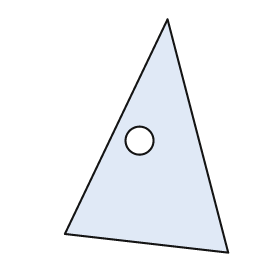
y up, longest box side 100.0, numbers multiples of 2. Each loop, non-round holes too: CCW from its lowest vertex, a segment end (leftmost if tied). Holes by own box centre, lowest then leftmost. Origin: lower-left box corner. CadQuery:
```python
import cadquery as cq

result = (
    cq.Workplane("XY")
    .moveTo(70.0, 0.0)
    .lineTo(44.0, 100.0)
    .lineTo(0.0, 8.0)
    .close()
    .moveTo(32.0, 48.0)
    .circle(6.0)
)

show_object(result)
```